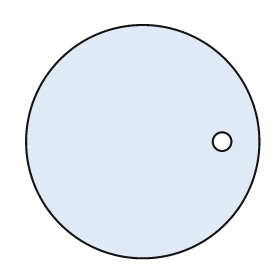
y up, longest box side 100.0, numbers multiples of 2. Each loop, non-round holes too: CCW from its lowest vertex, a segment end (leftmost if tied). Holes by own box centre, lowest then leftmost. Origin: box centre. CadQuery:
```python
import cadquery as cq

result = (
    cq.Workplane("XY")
    .moveTo(0.0, 0.0)
    .circle(50.0)
    .moveTo(34.0, 0.0)
    .circle(4.0)
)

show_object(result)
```